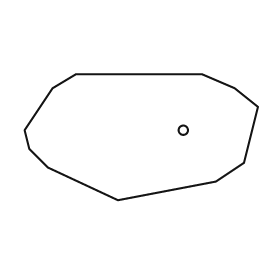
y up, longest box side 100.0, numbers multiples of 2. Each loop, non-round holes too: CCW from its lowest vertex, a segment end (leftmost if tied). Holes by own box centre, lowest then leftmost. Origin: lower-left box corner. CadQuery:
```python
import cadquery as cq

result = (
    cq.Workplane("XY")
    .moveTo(40.0, 0.0)
    .lineTo(82.0, 8.0)
    .lineTo(94.0, 16.0)
    .lineTo(100.0, 40.0)
    .lineTo(90.0, 48.0)
    .lineTo(76.0, 54.0)
    .lineTo(22.0, 54.0)
    .lineTo(12.0, 48.0)
    .lineTo(0.0, 30.0)
    .lineTo(2.0, 22.0)
    .lineTo(10.0, 14.0)
    .close()
    .moveTo(68.0, 30.0)
    .circle(2.0)
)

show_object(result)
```